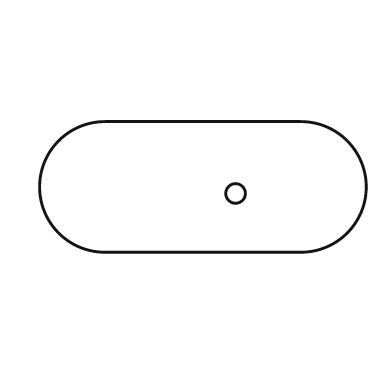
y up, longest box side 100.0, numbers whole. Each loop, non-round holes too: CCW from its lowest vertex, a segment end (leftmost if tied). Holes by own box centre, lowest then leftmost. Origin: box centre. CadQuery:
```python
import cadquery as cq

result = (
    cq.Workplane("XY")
    .moveTo(-30.0, -20.0)
    .lineTo(30.0, -20.0)
    .threePointArc((50.0, 0.0), (30.0, 20.0))
    .lineTo(-30.0, 20.0)
    .threePointArc((-50.0, 0.0), (-30.0, -20.0))
    .close()
    .moveTo(10.0, -2.0)
    .circle(3.0)
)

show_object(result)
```